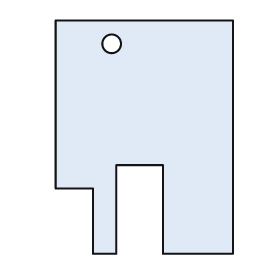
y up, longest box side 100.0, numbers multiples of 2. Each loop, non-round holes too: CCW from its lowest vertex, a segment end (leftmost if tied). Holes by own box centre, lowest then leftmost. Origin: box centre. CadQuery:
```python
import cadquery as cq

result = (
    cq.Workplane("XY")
    .moveTo(-22.0, -50.0)
    .lineTo(-12.0, -50.0)
    .lineTo(-12.0, -12.0)
    .lineTo(8.0, -12.0)
    .lineTo(8.0, -50.0)
    .lineTo(38.0, -50.0)
    .lineTo(38.0, 50.0)
    .lineTo(-38.0, 50.0)
    .lineTo(-38.0, -22.0)
    .lineTo(-22.0, -22.0)
    .close()
    .moveTo(-14.0, 40.0)
    .circle(4.0)
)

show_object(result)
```